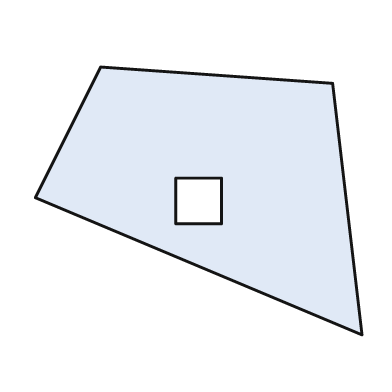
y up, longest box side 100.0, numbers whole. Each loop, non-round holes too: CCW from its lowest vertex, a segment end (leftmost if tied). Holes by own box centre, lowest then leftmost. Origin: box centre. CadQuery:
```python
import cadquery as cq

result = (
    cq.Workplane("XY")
    .moveTo(50.0, -41.0)
    .lineTo(41.0, 36.0)
    .lineTo(-30.0, 41.0)
    .lineTo(-50.0, 1.0)
    .close()
    .moveTo(-7.0, -7.0)
    .lineTo(7.0, -7.0)
    .lineTo(7.0, 7.0)
    .lineTo(-7.0, 7.0)
    .close()
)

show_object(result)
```